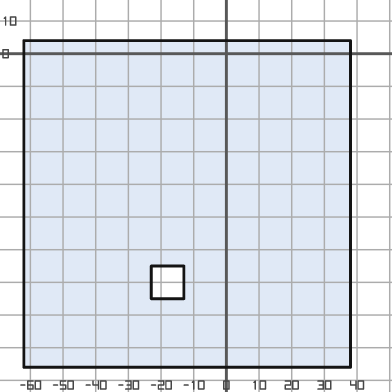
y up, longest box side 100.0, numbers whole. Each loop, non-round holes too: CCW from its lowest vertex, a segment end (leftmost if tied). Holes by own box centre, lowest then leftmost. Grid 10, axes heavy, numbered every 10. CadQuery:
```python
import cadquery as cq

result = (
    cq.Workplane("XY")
    .moveTo(-62.0, -96.0)
    .lineTo(38.0, -96.0)
    .lineTo(38.0, 4.0)
    .lineTo(-62.0, 4.0)
    .close()
    .moveTo(-23.0, -75.0)
    .lineTo(-13.0, -75.0)
    .lineTo(-13.0, -65.0)
    .lineTo(-23.0, -65.0)
    .close()
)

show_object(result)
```